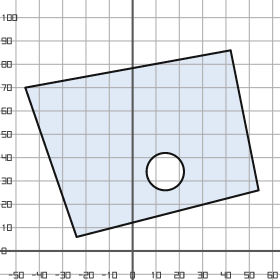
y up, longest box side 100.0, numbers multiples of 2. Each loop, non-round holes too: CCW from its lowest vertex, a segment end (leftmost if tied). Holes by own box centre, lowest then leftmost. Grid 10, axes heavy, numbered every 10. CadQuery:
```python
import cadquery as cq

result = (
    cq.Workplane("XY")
    .moveTo(-24.0, 6.0)
    .lineTo(54.0, 26.0)
    .lineTo(42.0, 86.0)
    .lineTo(-46.0, 70.0)
    .close()
    .moveTo(14.0, 34.0)
    .circle(8.0)
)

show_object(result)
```